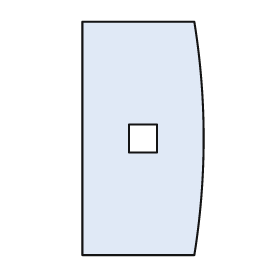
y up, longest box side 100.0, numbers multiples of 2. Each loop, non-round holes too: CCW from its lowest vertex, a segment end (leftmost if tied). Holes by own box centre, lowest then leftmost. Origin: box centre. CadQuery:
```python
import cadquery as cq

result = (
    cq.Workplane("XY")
    .moveTo(-26.0, -50.0)
    .lineTo(22.0, -50.0)
    .threePointArc((26.0, 0.0), (22.0, 50.0))
    .lineTo(-26.0, 50.0)
    .close()
    .moveTo(-6.0, -6.0)
    .lineTo(6.0, -6.0)
    .lineTo(6.0, 6.0)
    .lineTo(-6.0, 6.0)
    .close()
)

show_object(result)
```